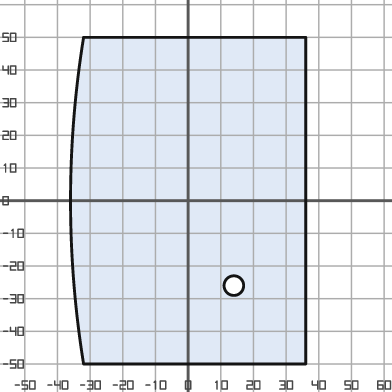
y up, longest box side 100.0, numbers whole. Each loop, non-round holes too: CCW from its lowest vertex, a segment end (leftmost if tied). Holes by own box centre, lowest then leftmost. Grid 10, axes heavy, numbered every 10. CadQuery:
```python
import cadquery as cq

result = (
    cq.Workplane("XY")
    .moveTo(-32.0, -50.0)
    .lineTo(36.0, -50.0)
    .lineTo(36.0, 50.0)
    .lineTo(-32.0, 50.0)
    .threePointArc((-36.0, 0.0), (-32.0, -50.0))
    .close()
    .moveTo(14.0, -26.0)
    .circle(3.0)
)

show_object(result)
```